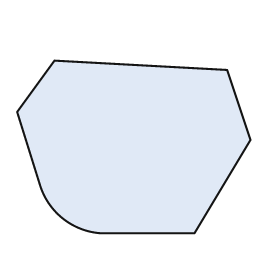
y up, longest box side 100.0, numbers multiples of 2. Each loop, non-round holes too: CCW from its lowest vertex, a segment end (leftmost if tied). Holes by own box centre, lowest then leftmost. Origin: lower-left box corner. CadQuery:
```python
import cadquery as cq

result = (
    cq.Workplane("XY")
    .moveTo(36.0, 0.0)
    .lineTo(76.0, 0.0)
    .lineTo(100.0, 40.0)
    .lineTo(90.0, 70.0)
    .lineTo(16.0, 74.0)
    .lineTo(0.0, 52.0)
    .lineTo(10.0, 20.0)
    .threePointArc((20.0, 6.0), (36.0, 0.0))
    .close()
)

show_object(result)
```